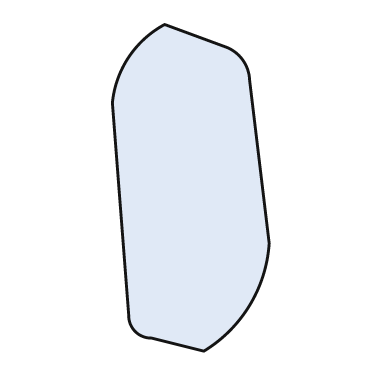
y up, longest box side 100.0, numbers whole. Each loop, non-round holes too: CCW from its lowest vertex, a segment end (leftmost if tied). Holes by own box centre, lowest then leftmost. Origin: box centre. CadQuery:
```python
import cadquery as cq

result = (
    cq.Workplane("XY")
    .moveTo(4.0, -50.0)
    .threePointArc((18.0, -36.0), (24.0, -17.0))
    .lineTo(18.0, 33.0)
    .threePointArc((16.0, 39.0), (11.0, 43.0))
    .lineTo(-8.0, 50.0)
    .threePointArc((-19.0, 40.0), (-24.0, 26.0))
    .lineTo(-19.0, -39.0)
    .threePointArc((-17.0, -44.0), (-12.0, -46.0))
    .close()
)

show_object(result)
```